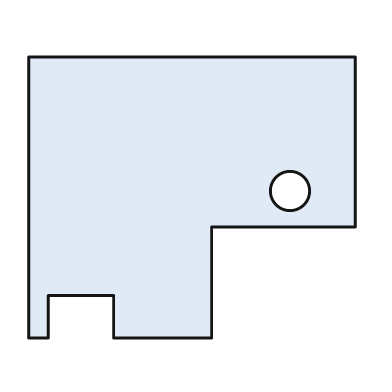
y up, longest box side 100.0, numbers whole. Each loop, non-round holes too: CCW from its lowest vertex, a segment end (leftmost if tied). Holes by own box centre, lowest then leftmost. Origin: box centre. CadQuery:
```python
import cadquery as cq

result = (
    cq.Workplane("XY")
    .moveTo(-50.0, -43.0)
    .lineTo(-44.0, -43.0)
    .lineTo(-44.0, -30.0)
    .lineTo(-24.0, -30.0)
    .lineTo(-24.0, -43.0)
    .lineTo(6.0, -43.0)
    .lineTo(6.0, -9.0)
    .lineTo(50.0, -9.0)
    .lineTo(50.0, 43.0)
    .lineTo(-50.0, 43.0)
    .close()
    .moveTo(30.0, 2.0)
    .circle(6.0)
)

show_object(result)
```